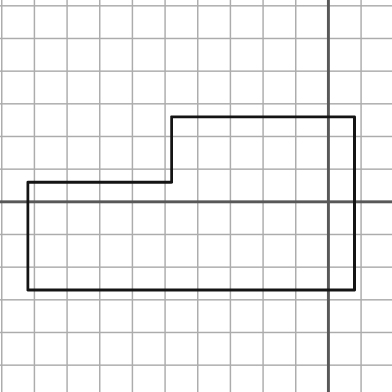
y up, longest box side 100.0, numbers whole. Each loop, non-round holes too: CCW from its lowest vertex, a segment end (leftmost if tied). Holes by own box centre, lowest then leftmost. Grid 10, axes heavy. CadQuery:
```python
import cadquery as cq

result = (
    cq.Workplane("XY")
    .moveTo(-92.0, -27.0)
    .lineTo(8.0, -27.0)
    .lineTo(8.0, 26.0)
    .lineTo(-48.0, 26.0)
    .lineTo(-48.0, 6.0)
    .lineTo(-92.0, 6.0)
    .close()
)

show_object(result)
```